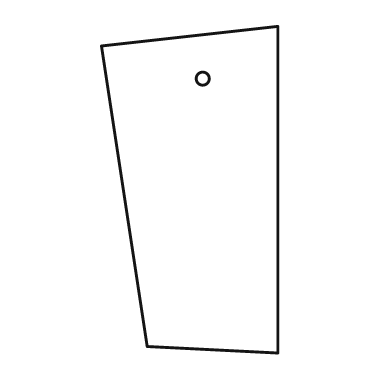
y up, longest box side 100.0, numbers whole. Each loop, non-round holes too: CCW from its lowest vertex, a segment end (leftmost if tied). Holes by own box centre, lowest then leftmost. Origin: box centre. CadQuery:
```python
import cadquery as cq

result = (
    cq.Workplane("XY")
    .moveTo(27.0, -50.0)
    .lineTo(27.0, 50.0)
    .lineTo(-27.0, 44.0)
    .lineTo(-13.0, -48.0)
    .close()
    .moveTo(4.0, 34.0)
    .circle(2.0)
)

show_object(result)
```